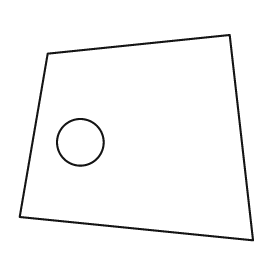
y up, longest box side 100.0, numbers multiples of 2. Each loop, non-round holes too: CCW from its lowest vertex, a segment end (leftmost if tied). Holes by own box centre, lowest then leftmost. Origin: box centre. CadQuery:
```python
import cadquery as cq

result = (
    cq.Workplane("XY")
    .moveTo(50.0, -44.0)
    .lineTo(40.0, 44.0)
    .lineTo(-38.0, 36.0)
    .lineTo(-50.0, -34.0)
    .close()
    .moveTo(-24.0, -2.0)
    .circle(10.0)
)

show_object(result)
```